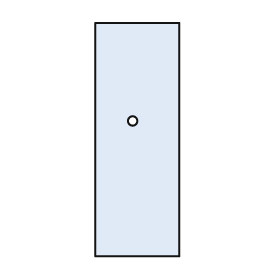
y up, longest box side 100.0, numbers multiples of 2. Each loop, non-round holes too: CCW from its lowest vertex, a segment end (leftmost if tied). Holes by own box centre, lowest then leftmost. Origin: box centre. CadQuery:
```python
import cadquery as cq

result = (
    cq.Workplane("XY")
    .moveTo(-18.0, -50.0)
    .lineTo(18.0, -50.0)
    .lineTo(18.0, 50.0)
    .lineTo(-18.0, 50.0)
    .close()
    .moveTo(-2.0, 8.0)
    .circle(2.0)
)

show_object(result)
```